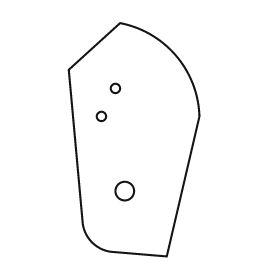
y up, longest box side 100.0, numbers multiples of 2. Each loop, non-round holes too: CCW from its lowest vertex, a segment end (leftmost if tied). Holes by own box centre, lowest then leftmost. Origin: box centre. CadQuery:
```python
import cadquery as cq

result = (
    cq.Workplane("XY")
    .moveTo(14.0, -50.0)
    .lineTo(28.0, 10.0)
    .threePointArc((18.0, 36.0), (-6.0, 50.0))
    .lineTo(-28.0, 30.0)
    .lineTo(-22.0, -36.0)
    .threePointArc((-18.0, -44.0), (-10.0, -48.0))
    .close()
    .moveTo(-4.0, -22.0)
    .circle(4.0)
    .moveTo(-14.0, 10.0)
    .circle(2.0)
    .moveTo(-8.0, 22.0)
    .circle(2.0)
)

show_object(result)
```